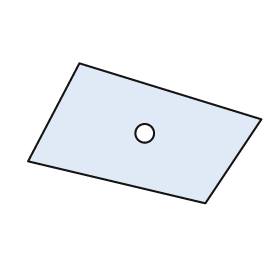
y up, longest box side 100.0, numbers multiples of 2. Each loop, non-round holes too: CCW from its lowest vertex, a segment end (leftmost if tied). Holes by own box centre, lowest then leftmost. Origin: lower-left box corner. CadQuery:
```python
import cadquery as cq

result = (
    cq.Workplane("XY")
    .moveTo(76.0, 0.0)
    .lineTo(100.0, 36.0)
    .lineTo(22.0, 60.0)
    .lineTo(0.0, 18.0)
    .close()
    .moveTo(50.0, 30.0)
    .circle(4.0)
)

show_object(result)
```